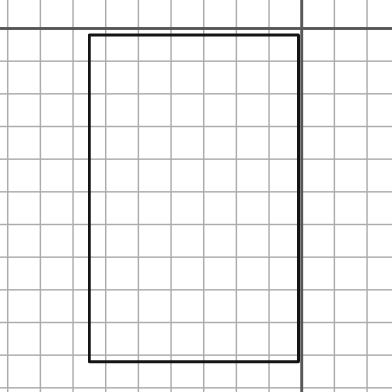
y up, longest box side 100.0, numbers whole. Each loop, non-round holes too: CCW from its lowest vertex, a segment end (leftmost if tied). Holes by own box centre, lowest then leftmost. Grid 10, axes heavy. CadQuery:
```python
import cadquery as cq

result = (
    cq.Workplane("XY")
    .moveTo(-65.0, -102.0)
    .lineTo(-1.0, -102.0)
    .lineTo(-1.0, -2.0)
    .lineTo(-65.0, -2.0)
    .close()
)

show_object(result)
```